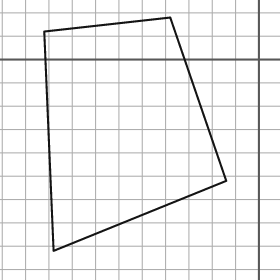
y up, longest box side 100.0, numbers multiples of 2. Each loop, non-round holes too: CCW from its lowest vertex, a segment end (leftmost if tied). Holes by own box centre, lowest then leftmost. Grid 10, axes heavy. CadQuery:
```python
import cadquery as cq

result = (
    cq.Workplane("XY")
    .moveTo(-88.0, -82.0)
    .lineTo(-14.0, -52.0)
    .lineTo(-38.0, 18.0)
    .lineTo(-92.0, 12.0)
    .close()
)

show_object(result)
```